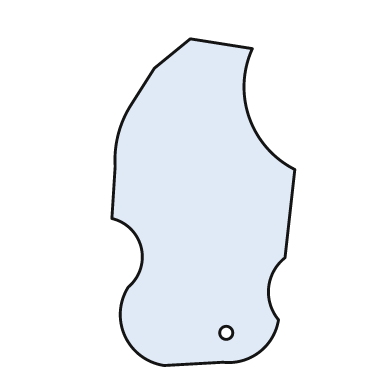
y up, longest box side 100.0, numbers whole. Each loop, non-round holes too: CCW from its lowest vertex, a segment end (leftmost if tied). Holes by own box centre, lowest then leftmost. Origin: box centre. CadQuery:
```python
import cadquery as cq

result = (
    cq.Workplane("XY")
    .moveTo(-12.0, -50.0)
    .lineTo(6.0, -49.0)
    .threePointArc((17.0, -46.0), (23.0, -36.0))
    .threePointArc((20.0, -26.0), (25.0, -17.0))
    .lineTo(28.0, 10.0)
    .threePointArc((14.0, 26.0), (15.0, 47.0))
    .lineTo(-4.0, 50.0)
    .lineTo(-15.0, 41.0)
    .lineTo(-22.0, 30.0)
    .threePointArc((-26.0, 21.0), (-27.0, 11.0))
    .lineTo(-28.0, -5.0)
    .threePointArc((-19.0, -14.0), (-23.0, -26.0))
    .threePointArc((-24.0, -41.0), (-12.0, -50.0))
    .close()
    .moveTo(7.0, -40.0)
    .circle(2.0)
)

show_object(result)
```